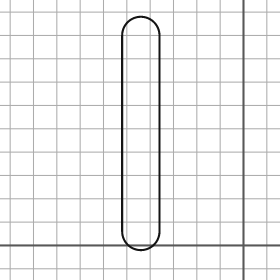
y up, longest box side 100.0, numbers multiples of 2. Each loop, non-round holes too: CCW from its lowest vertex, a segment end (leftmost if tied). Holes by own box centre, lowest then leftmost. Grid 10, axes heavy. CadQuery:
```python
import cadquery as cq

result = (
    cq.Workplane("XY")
    .moveTo(-52.0, 6.0)
    .threePointArc((-44.0, -2.0), (-36.0, 6.0))
    .lineTo(-36.0, 90.0)
    .threePointArc((-44.0, 98.0), (-52.0, 90.0))
    .close()
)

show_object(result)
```